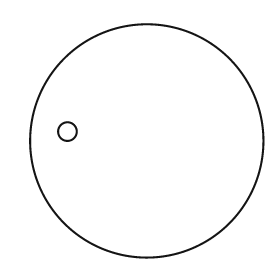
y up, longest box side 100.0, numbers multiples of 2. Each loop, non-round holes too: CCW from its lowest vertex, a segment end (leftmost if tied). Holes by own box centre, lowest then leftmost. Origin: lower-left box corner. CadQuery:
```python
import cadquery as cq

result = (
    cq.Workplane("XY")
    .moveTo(50.0, 50.0)
    .circle(50.0)
    .moveTo(16.0, 54.0)
    .circle(4.0)
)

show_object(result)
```